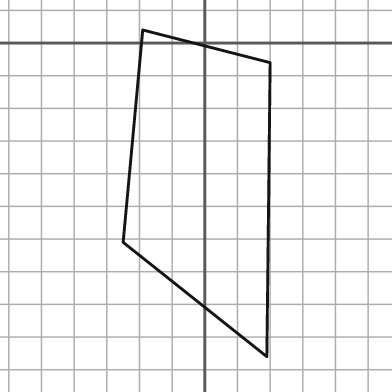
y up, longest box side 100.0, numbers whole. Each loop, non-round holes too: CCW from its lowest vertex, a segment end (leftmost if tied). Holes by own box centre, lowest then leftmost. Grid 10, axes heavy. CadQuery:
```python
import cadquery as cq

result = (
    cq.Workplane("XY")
    .moveTo(19.0, -96.0)
    .lineTo(20.0, -6.0)
    .lineTo(-19.0, 4.0)
    .lineTo(-25.0, -61.0)
    .close()
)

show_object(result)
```